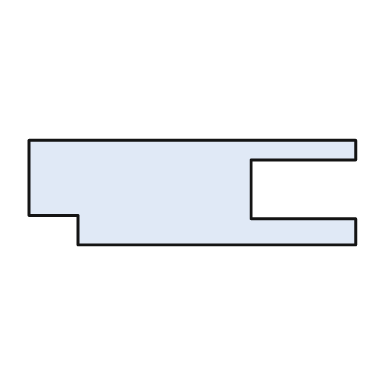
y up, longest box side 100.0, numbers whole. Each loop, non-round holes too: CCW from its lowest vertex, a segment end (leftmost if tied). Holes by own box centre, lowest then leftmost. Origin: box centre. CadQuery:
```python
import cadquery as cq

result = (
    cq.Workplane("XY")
    .moveTo(-35.0, -16.0)
    .lineTo(50.0, -16.0)
    .lineTo(50.0, -8.0)
    .lineTo(18.0, -8.0)
    .lineTo(18.0, 10.0)
    .lineTo(50.0, 10.0)
    .lineTo(50.0, 16.0)
    .lineTo(-50.0, 16.0)
    .lineTo(-50.0, -7.0)
    .lineTo(-35.0, -7.0)
    .close()
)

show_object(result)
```